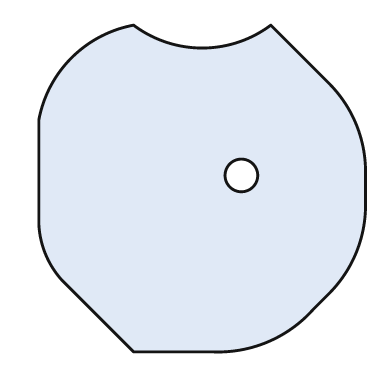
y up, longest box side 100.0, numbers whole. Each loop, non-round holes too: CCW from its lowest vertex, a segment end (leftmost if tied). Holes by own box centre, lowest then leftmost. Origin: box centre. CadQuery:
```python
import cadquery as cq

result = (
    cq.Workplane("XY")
    .moveTo(-21.0, -50.0)
    .lineTo(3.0, -50.0)
    .threePointArc((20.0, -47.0), (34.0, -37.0))
    .lineTo(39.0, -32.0)
    .threePointArc((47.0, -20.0), (50.0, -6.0))
    .lineTo(50.0, 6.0)
    .threePointArc((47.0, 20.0), (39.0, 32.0))
    .lineTo(21.0, 50.0)
    .threePointArc((0.0, 43.0), (-21.0, 50.0))
    .threePointArc((-40.0, 40.0), (-50.0, 21.0))
    .lineTo(-50.0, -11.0)
    .threePointArc((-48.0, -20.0), (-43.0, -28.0))
    .close()
    .moveTo(12.0, 4.0)
    .circle(5.0)
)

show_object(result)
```